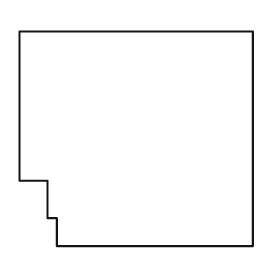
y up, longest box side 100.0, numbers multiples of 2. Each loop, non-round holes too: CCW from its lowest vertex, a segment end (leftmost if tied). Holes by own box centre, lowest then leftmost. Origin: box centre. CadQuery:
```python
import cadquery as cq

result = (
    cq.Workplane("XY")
    .moveTo(-34.0, -46.0)
    .lineTo(50.0, -46.0)
    .lineTo(50.0, 46.0)
    .lineTo(-50.0, 46.0)
    .lineTo(-50.0, -18.0)
    .lineTo(-38.0, -18.0)
    .lineTo(-38.0, -34.0)
    .lineTo(-34.0, -34.0)
    .close()
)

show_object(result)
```